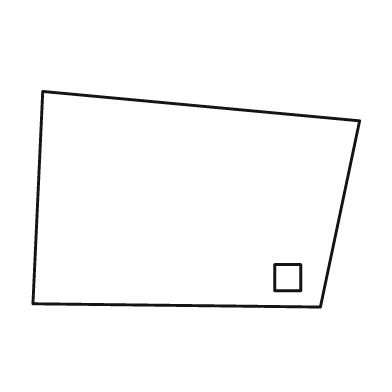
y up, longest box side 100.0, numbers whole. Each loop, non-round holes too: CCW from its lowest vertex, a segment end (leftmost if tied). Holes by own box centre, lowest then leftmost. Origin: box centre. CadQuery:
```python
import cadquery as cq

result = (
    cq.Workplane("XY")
    .moveTo(38.0, -33.0)
    .lineTo(50.0, 24.0)
    .lineTo(-47.0, 33.0)
    .lineTo(-50.0, -32.0)
    .close()
    .moveTo(24.0, -28.0)
    .lineTo(32.0, -28.0)
    .lineTo(32.0, -20.0)
    .lineTo(24.0, -20.0)
    .close()
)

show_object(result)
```